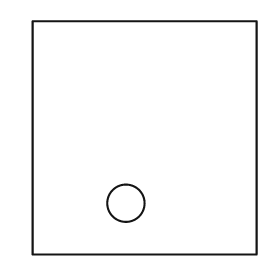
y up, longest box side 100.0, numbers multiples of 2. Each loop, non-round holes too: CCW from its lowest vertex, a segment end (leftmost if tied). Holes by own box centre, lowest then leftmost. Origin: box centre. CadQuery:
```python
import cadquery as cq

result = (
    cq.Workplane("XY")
    .moveTo(-48.0, -50.0)
    .lineTo(48.0, -50.0)
    .lineTo(48.0, 50.0)
    .lineTo(-48.0, 50.0)
    .close()
    .moveTo(-8.0, -28.0)
    .circle(8.0)
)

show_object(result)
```